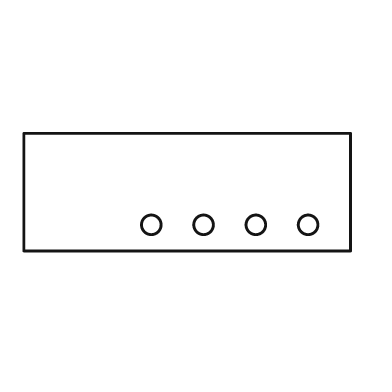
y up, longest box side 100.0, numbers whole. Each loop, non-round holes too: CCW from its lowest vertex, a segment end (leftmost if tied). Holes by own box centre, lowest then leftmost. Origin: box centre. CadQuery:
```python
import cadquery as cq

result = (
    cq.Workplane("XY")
    .moveTo(-50.0, -18.0)
    .lineTo(50.0, -18.0)
    .lineTo(50.0, 18.0)
    .lineTo(-50.0, 18.0)
    .close()
    .moveTo(-11.0, -10.0)
    .circle(3.0)
    .moveTo(5.0, -10.0)
    .circle(3.0)
    .moveTo(21.0, -10.0)
    .circle(3.0)
    .moveTo(37.0, -10.0)
    .circle(3.0)
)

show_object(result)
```